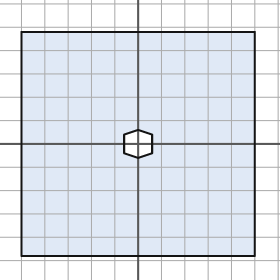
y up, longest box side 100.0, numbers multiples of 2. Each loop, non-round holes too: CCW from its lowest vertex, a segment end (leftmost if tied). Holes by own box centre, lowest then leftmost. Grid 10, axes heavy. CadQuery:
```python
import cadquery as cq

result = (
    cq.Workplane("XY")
    .moveTo(-50.0, -48.0)
    .lineTo(50.0, -48.0)
    .lineTo(50.0, 48.0)
    .lineTo(-50.0, 48.0)
    .close()
    .moveTo(0.0, -6.0)
    .lineTo(6.0, -4.0)
    .lineTo(6.0, 4.0)
    .lineTo(0.0, 6.0)
    .lineTo(-6.0, 4.0)
    .lineTo(-6.0, -4.0)
    .close()
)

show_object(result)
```